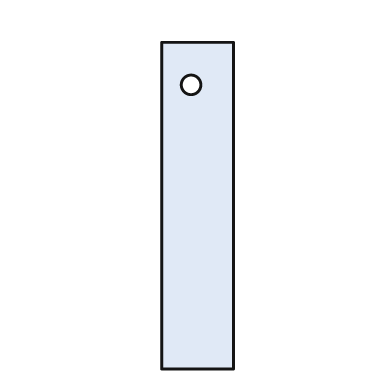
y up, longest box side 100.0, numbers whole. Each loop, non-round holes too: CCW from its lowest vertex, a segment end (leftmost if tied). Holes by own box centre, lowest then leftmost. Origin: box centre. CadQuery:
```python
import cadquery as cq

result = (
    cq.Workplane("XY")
    .moveTo(-11.0, -50.0)
    .lineTo(11.0, -50.0)
    .lineTo(11.0, 50.0)
    .lineTo(-11.0, 50.0)
    .close()
    .moveTo(-2.0, 37.0)
    .circle(3.0)
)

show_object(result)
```